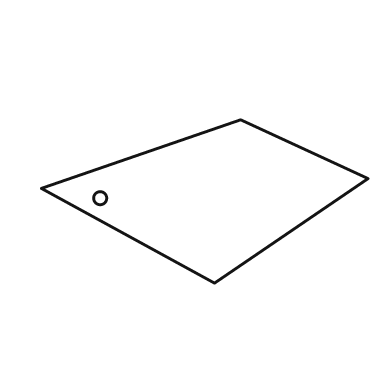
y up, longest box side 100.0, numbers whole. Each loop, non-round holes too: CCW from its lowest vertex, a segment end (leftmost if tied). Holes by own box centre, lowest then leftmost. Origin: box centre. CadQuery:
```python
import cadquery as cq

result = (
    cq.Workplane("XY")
    .moveTo(3.0, -25.0)
    .lineTo(50.0, 7.0)
    .lineTo(11.0, 25.0)
    .lineTo(-50.0, 4.0)
    .close()
    .moveTo(-32.0, 1.0)
    .circle(2.0)
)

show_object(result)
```